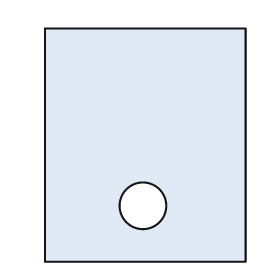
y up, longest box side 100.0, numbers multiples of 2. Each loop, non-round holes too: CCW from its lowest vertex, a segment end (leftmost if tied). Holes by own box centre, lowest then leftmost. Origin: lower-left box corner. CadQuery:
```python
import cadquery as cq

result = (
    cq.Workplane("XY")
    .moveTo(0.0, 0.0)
    .lineTo(86.0, 0.0)
    .lineTo(86.0, 100.0)
    .lineTo(0.0, 100.0)
    .close()
    .moveTo(42.0, 24.0)
    .circle(10.0)
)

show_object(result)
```